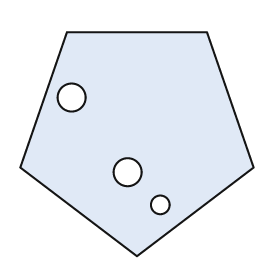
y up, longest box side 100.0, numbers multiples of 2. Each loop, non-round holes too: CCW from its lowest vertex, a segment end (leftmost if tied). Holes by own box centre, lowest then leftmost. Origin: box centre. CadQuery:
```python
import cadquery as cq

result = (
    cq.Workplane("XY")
    .moveTo(0.0, -48.0)
    .lineTo(50.0, -10.0)
    .lineTo(30.0, 48.0)
    .lineTo(-30.0, 48.0)
    .lineTo(-50.0, -10.0)
    .close()
    .moveTo(10.0, -26.0)
    .circle(4.0)
    .moveTo(-4.0, -12.0)
    .circle(6.0)
    .moveTo(-28.0, 20.0)
    .circle(6.0)
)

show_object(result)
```